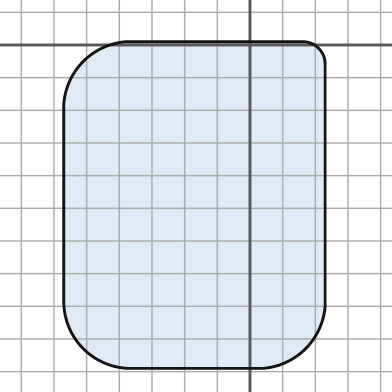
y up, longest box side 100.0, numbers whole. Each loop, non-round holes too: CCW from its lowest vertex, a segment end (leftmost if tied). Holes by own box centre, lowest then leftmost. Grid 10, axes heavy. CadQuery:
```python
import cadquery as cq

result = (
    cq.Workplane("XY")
    .moveTo(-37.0, -99.0)
    .lineTo(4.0, -99.0)
    .threePointArc((17.0, -93.0), (23.0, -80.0))
    .lineTo(23.0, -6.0)
    .threePointArc((21.0, -1.0), (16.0, 1.0))
    .lineTo(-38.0, 1.0)
    .threePointArc((-51.0, -5.0), (-57.0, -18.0))
    .lineTo(-57.0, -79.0)
    .threePointArc((-51.0, -93.0), (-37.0, -99.0))
    .close()
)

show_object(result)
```